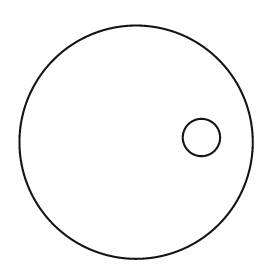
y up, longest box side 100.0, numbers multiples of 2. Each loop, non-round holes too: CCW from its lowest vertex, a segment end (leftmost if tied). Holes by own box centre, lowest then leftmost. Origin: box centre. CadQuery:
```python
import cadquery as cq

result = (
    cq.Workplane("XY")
    .moveTo(0.0, 0.0)
    .circle(50.0)
    .moveTo(28.0, 2.0)
    .circle(8.0)
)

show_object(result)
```